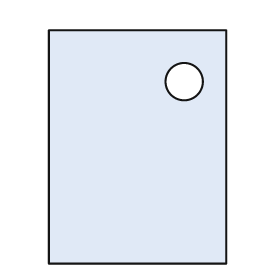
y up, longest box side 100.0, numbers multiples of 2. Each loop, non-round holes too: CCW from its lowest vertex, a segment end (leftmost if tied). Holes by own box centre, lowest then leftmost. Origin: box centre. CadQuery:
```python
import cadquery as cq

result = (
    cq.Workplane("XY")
    .moveTo(-38.0, -50.0)
    .lineTo(38.0, -50.0)
    .lineTo(38.0, 50.0)
    .lineTo(-38.0, 50.0)
    .close()
    .moveTo(20.0, 28.0)
    .circle(8.0)
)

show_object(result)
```